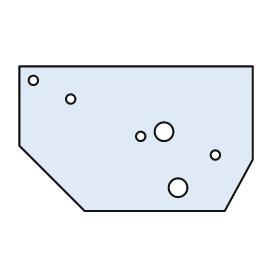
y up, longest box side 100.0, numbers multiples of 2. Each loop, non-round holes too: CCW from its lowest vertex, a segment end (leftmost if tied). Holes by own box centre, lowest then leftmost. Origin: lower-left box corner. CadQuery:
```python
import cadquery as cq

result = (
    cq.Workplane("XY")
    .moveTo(28.0, 0.0)
    .lineTo(88.0, 0.0)
    .lineTo(100.0, 22.0)
    .lineTo(100.0, 62.0)
    .lineTo(0.0, 62.0)
    .lineTo(0.0, 28.0)
    .close()
    .moveTo(68.0, 10.0)
    .circle(4.0)
    .moveTo(84.0, 24.0)
    .circle(2.0)
    .moveTo(52.0, 32.0)
    .circle(2.0)
    .moveTo(62.0, 34.0)
    .circle(4.0)
    .moveTo(22.0, 48.0)
    .circle(2.0)
    .moveTo(6.0, 56.0)
    .circle(2.0)
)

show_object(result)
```